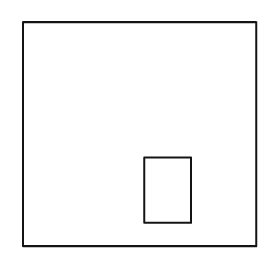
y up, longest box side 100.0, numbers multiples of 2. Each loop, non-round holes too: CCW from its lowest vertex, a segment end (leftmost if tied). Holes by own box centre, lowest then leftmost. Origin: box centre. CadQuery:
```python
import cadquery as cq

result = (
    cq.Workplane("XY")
    .moveTo(-50.0, -48.0)
    .lineTo(50.0, -48.0)
    .lineTo(50.0, 48.0)
    .lineTo(-50.0, 48.0)
    .close()
    .moveTo(2.0, -38.0)
    .lineTo(22.0, -38.0)
    .lineTo(22.0, -10.0)
    .lineTo(2.0, -10.0)
    .close()
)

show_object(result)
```